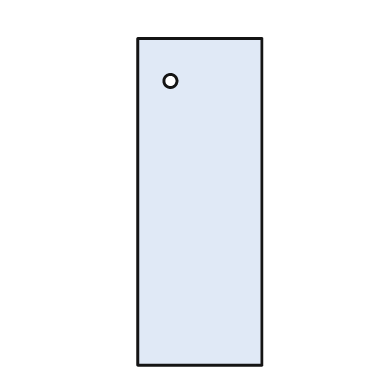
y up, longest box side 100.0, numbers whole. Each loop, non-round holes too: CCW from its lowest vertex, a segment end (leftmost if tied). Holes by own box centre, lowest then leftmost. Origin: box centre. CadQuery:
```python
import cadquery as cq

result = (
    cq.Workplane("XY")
    .moveTo(-19.0, -50.0)
    .lineTo(19.0, -50.0)
    .lineTo(19.0, 50.0)
    .lineTo(-19.0, 50.0)
    .close()
    .moveTo(-9.0, 37.0)
    .circle(2.0)
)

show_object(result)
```